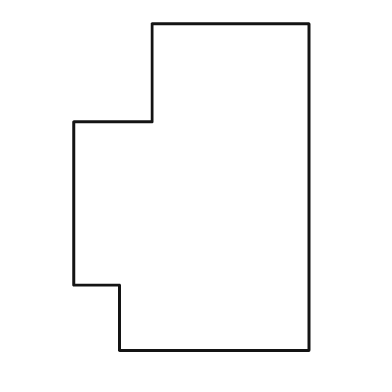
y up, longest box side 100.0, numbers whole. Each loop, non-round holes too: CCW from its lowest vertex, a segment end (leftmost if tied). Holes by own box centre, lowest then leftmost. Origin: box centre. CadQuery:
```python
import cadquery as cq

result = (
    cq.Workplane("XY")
    .moveTo(-22.0, -50.0)
    .lineTo(36.0, -50.0)
    .lineTo(36.0, 50.0)
    .lineTo(-12.0, 50.0)
    .lineTo(-12.0, 20.0)
    .lineTo(-36.0, 20.0)
    .lineTo(-36.0, -30.0)
    .lineTo(-22.0, -30.0)
    .close()
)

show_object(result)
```